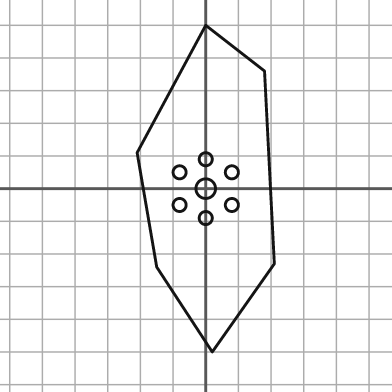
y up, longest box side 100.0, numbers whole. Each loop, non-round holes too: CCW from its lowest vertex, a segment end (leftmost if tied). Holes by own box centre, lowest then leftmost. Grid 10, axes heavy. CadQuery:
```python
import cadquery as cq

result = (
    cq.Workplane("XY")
    .moveTo(2.0, -50.0)
    .lineTo(21.0, -23.0)
    .lineTo(18.0, 36.0)
    .lineTo(0.0, 50.0)
    .lineTo(-21.0, 11.0)
    .lineTo(-15.0, -24.0)
    .close()
    .moveTo(0.0, -9.0)
    .circle(2.0)
    .moveTo(-8.0, -5.0)
    .circle(2.0)
    .moveTo(8.0, -5.0)
    .circle(2.0)
    .moveTo(0.0, 0.0)
    .circle(3.0)
    .moveTo(-8.0, 5.0)
    .circle(2.0)
    .moveTo(8.0, 5.0)
    .circle(2.0)
    .moveTo(0.0, 9.0)
    .circle(2.0)
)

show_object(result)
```